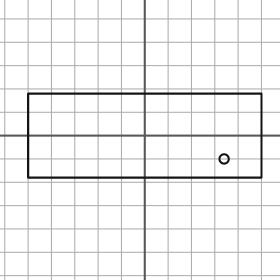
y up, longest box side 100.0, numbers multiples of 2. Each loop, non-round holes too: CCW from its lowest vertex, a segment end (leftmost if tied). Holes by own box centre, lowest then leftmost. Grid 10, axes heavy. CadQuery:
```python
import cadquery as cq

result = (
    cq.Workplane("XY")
    .moveTo(-50.0, -18.0)
    .lineTo(50.0, -18.0)
    .lineTo(50.0, 18.0)
    .lineTo(-50.0, 18.0)
    .close()
    .moveTo(34.0, -10.0)
    .circle(2.0)
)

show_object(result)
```